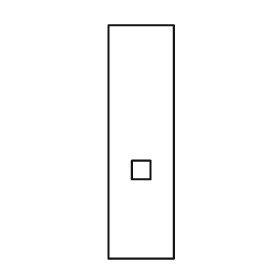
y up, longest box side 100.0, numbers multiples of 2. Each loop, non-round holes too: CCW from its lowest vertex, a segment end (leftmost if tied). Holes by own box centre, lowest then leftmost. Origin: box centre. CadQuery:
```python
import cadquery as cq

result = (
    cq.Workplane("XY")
    .moveTo(-14.0, -50.0)
    .lineTo(14.0, -50.0)
    .lineTo(14.0, 50.0)
    .lineTo(-14.0, 50.0)
    .close()
    .moveTo(-4.0, -16.0)
    .lineTo(4.0, -16.0)
    .lineTo(4.0, -8.0)
    .lineTo(-4.0, -8.0)
    .close()
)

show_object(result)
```